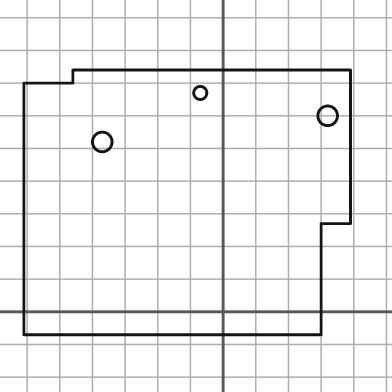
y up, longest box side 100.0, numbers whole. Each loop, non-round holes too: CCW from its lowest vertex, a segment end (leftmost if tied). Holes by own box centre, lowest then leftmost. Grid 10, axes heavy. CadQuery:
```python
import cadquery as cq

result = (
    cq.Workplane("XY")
    .moveTo(-61.0, -7.0)
    .lineTo(30.0, -7.0)
    .lineTo(30.0, 27.0)
    .lineTo(39.0, 27.0)
    .lineTo(39.0, 74.0)
    .lineTo(-46.0, 74.0)
    .lineTo(-46.0, 70.0)
    .lineTo(-61.0, 70.0)
    .close()
    .moveTo(-37.0, 52.0)
    .circle(3.0)
    .moveTo(32.0, 60.0)
    .circle(3.0)
    .moveTo(-7.0, 67.0)
    .circle(2.0)
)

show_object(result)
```